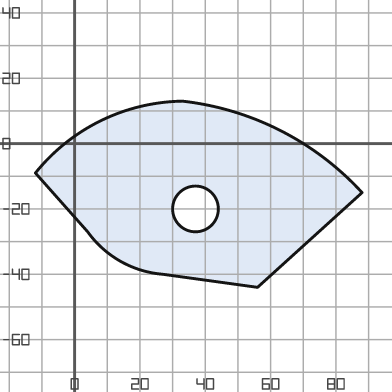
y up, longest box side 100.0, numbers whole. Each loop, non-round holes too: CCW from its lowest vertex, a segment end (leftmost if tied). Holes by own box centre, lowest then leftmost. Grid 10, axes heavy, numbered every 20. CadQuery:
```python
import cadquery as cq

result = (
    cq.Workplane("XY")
    .moveTo(56.0, -44.0)
    .lineTo(88.0, -15.0)
    .threePointArc((63.0, 4.0), (33.0, 13.0))
    .threePointArc((8.0, 7.0), (-12.0, -9.0))
    .lineTo(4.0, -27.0)
    .threePointArc((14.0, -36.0), (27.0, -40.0))
    .close()
    .moveTo(37.0, -20.0)
    .circle(7.0)
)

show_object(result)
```